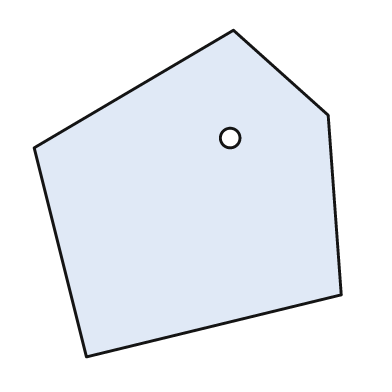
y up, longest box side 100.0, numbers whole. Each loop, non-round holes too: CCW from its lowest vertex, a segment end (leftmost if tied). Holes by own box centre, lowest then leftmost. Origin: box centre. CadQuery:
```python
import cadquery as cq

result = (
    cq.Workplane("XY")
    .moveTo(-31.0, -50.0)
    .lineTo(47.0, -31.0)
    .lineTo(43.0, 24.0)
    .lineTo(14.0, 50.0)
    .lineTo(-47.0, 14.0)
    .close()
    .moveTo(13.0, 17.0)
    .circle(3.0)
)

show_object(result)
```